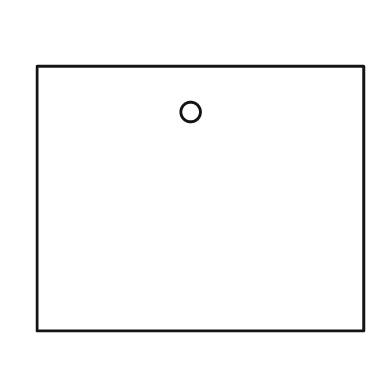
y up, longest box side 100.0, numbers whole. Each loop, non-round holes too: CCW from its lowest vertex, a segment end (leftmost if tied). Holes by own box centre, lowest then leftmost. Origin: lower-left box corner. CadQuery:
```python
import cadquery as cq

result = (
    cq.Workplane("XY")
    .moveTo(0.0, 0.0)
    .lineTo(100.0, 0.0)
    .lineTo(100.0, 81.0)
    .lineTo(0.0, 81.0)
    .close()
    .moveTo(47.0, 67.0)
    .circle(3.0)
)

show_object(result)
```